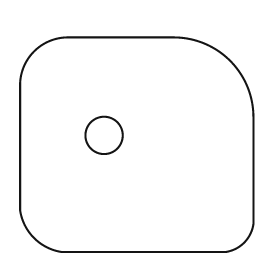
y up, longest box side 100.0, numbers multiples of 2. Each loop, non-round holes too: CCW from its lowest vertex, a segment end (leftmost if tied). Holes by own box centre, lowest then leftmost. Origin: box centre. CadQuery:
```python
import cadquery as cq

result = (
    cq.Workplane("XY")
    .moveTo(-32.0, -46.0)
    .lineTo(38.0, -46.0)
    .threePointArc((46.0, -42.0), (50.0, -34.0))
    .lineTo(50.0, 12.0)
    .threePointArc((40.0, 36.0), (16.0, 46.0))
    .lineTo(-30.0, 46.0)
    .threePointArc((-44.0, 40.0), (-50.0, 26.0))
    .lineTo(-50.0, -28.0)
    .threePointArc((-44.0, -40.0), (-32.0, -46.0))
    .close()
    .moveTo(-14.0, 4.0)
    .circle(8.0)
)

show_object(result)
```